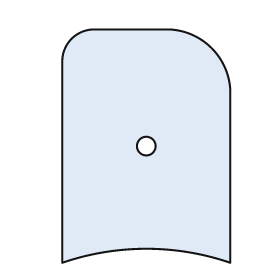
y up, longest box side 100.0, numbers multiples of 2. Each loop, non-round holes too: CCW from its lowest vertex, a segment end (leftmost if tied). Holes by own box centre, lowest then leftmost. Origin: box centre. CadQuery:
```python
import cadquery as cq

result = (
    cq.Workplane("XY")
    .moveTo(-36.0, -50.0)
    .threePointArc((0.0, -44.0), (36.0, -50.0))
    .lineTo(36.0, 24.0)
    .threePointArc((28.0, 42.0), (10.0, 50.0))
    .lineTo(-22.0, 50.0)
    .threePointArc((-32.0, 46.0), (-36.0, 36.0))
    .close()
    .moveTo(0.0, 0.0)
    .circle(4.0)
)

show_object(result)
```